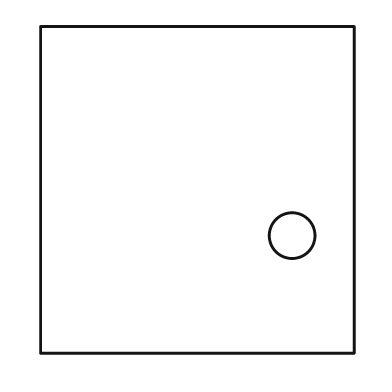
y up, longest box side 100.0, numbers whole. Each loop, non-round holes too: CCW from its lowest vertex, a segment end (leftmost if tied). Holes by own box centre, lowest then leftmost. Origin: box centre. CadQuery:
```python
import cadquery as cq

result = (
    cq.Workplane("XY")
    .moveTo(-48.0, -50.0)
    .lineTo(48.0, -50.0)
    .lineTo(48.0, 50.0)
    .lineTo(-48.0, 50.0)
    .close()
    .moveTo(29.0, -14.0)
    .circle(7.0)
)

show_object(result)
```